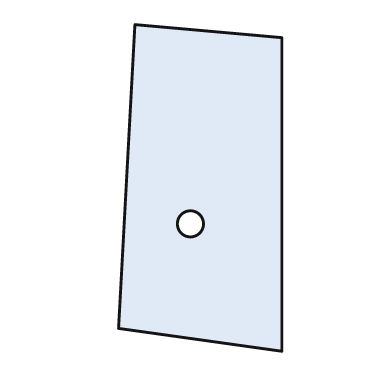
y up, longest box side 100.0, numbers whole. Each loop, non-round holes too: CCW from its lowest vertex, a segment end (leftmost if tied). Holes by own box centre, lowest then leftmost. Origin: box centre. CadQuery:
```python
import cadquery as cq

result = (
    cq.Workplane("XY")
    .moveTo(25.0, -50.0)
    .lineTo(25.0, 46.0)
    .lineTo(-20.0, 50.0)
    .lineTo(-25.0, -43.0)
    .close()
    .moveTo(-3.0, -11.0)
    .circle(4.0)
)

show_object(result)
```